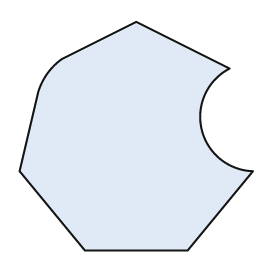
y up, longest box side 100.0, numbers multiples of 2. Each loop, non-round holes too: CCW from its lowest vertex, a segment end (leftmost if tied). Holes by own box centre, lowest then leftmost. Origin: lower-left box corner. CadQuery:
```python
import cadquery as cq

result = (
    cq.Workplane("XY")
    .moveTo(28.0, 0.0)
    .lineTo(72.0, 0.0)
    .lineTo(100.0, 34.0)
    .threePointArc((78.0, 52.0), (90.0, 78.0))
    .lineTo(50.0, 98.0)
    .lineTo(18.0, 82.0)
    .threePointArc((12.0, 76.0), (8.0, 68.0))
    .lineTo(0.0, 34.0)
    .close()
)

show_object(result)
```